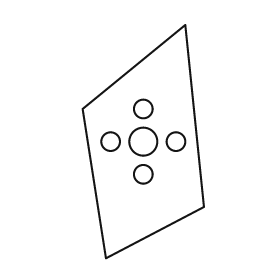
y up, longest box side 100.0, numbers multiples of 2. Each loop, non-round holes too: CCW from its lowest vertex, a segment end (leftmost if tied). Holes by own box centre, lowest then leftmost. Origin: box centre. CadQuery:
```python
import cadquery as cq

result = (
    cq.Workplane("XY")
    .moveTo(-16.0, -50.0)
    .lineTo(26.0, -28.0)
    .lineTo(18.0, 50.0)
    .lineTo(-26.0, 14.0)
    .close()
    .moveTo(0.0, -14.0)
    .circle(4.0)
    .moveTo(-14.0, 0.0)
    .circle(4.0)
    .moveTo(0.0, 0.0)
    .circle(6.0)
    .moveTo(14.0, 0.0)
    .circle(4.0)
    .moveTo(0.0, 14.0)
    .circle(4.0)
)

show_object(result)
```